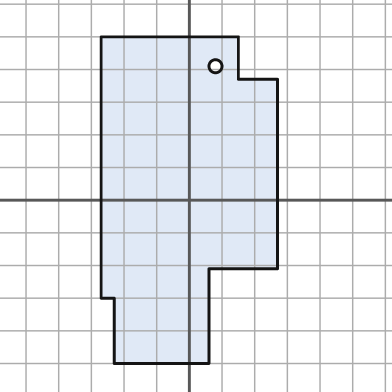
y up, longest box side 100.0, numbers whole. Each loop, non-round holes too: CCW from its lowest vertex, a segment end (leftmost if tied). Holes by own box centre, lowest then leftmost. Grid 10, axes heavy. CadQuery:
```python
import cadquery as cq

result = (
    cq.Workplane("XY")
    .moveTo(-23.0, -50.0)
    .lineTo(6.0, -50.0)
    .lineTo(6.0, -21.0)
    .lineTo(27.0, -21.0)
    .lineTo(27.0, 37.0)
    .lineTo(15.0, 37.0)
    .lineTo(15.0, 50.0)
    .lineTo(-27.0, 50.0)
    .lineTo(-27.0, -30.0)
    .lineTo(-23.0, -30.0)
    .close()
    .moveTo(8.0, 41.0)
    .circle(2.0)
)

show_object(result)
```